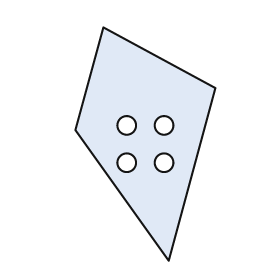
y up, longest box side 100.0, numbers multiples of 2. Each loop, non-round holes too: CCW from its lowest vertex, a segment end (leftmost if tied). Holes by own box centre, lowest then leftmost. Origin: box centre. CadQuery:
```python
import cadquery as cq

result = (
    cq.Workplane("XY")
    .moveTo(10.0, -50.0)
    .lineTo(30.0, 24.0)
    .lineTo(-18.0, 50.0)
    .lineTo(-30.0, 6.0)
    .close()
    .moveTo(-8.0, -8.0)
    .circle(4.0)
    .moveTo(8.0, -8.0)
    .circle(4.0)
    .moveTo(-8.0, 8.0)
    .circle(4.0)
    .moveTo(8.0, 8.0)
    .circle(4.0)
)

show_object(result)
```